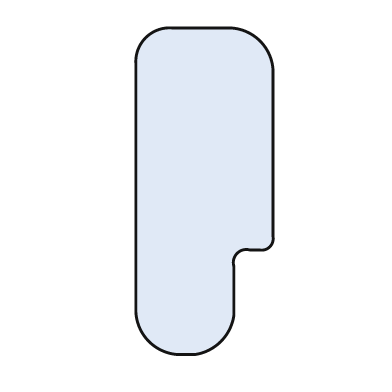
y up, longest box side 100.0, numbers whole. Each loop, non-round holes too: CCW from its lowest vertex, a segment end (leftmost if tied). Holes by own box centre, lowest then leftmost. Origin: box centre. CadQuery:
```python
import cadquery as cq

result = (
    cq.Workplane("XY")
    .moveTo(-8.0, -50.0)
    .lineTo(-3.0, -50.0)
    .threePointArc((5.0, -46.0), (9.0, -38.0))
    .lineTo(9.0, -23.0)
    .threePointArc((10.0, -19.0), (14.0, -18.0))
    .lineTo(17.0, -18.0)
    .threePointArc((20.0, -17.0), (21.0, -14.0))
    .lineTo(21.0, 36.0)
    .threePointArc((17.0, 46.0), (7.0, 50.0))
    .lineTo(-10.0, 50.0)
    .threePointArc((-18.0, 47.0), (-21.0, 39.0))
    .lineTo(-21.0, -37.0)
    .threePointArc((-17.0, -46.0), (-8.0, -50.0))
    .close()
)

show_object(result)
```